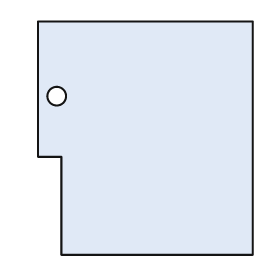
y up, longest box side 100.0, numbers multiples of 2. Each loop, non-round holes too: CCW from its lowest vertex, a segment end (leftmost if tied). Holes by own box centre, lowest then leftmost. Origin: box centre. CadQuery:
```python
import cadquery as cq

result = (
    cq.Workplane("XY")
    .moveTo(-36.0, -50.0)
    .lineTo(46.0, -50.0)
    .lineTo(46.0, 50.0)
    .lineTo(-46.0, 50.0)
    .lineTo(-46.0, -8.0)
    .lineTo(-36.0, -8.0)
    .close()
    .moveTo(-38.0, 18.0)
    .circle(4.0)
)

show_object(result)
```